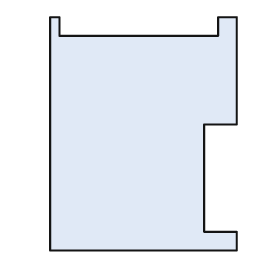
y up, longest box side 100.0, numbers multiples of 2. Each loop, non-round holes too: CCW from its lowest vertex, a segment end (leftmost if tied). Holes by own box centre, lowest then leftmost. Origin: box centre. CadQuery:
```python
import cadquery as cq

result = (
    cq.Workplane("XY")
    .moveTo(-40.0, -50.0)
    .lineTo(40.0, -50.0)
    .lineTo(40.0, -42.0)
    .lineTo(26.0, -42.0)
    .lineTo(26.0, 4.0)
    .lineTo(40.0, 4.0)
    .lineTo(40.0, 50.0)
    .lineTo(32.0, 50.0)
    .lineTo(32.0, 42.0)
    .lineTo(-36.0, 42.0)
    .lineTo(-36.0, 50.0)
    .lineTo(-40.0, 50.0)
    .close()
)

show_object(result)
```